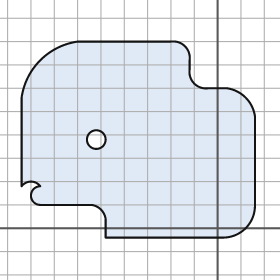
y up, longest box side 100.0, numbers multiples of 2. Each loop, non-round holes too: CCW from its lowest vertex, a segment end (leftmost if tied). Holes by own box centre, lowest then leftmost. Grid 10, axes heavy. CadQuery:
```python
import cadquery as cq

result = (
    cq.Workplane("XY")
    .moveTo(-48.0, -4.0)
    .lineTo(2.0, -4.0)
    .threePointArc((12.0, 0.0), (16.0, 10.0))
    .lineTo(16.0, 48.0)
    .threePointArc((12.0, 56.0), (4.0, 60.0))
    .lineTo(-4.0, 60.0)
    .threePointArc((-10.0, 62.0), (-12.0, 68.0))
    .lineTo(-12.0, 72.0)
    .threePointArc((-14.0, 78.0), (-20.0, 80.0))
    .lineTo(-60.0, 80.0)
    .threePointArc((-76.0, 72.0), (-84.0, 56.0))
    .lineTo(-84.0, 18.0)
    .threePointArc((-80.0, 20.0), (-76.0, 18.0))
    .threePointArc((-80.0, 14.0), (-76.0, 10.0))
    .lineTo(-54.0, 10.0)
    .threePointArc((-50.0, 8.0), (-48.0, 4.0))
    .close()
    .moveTo(-52.0, 38.0)
    .circle(4.0)
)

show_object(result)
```